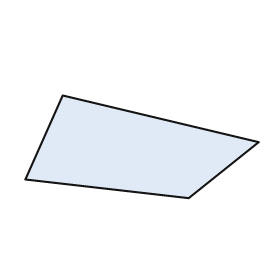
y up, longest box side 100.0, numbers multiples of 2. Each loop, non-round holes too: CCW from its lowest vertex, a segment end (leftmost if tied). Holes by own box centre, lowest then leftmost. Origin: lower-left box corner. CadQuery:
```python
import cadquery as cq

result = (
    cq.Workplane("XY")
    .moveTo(70.0, 0.0)
    .lineTo(100.0, 24.0)
    .lineTo(16.0, 44.0)
    .lineTo(0.0, 8.0)
    .close()
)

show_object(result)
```